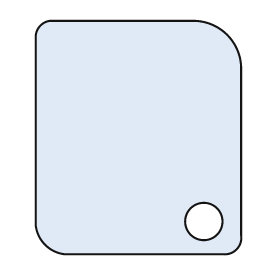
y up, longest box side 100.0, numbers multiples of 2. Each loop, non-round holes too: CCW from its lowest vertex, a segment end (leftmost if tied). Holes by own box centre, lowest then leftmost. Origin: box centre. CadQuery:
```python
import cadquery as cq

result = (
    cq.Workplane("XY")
    .moveTo(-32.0, -50.0)
    .lineTo(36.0, -50.0)
    .threePointArc((42.0, -48.0), (44.0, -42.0))
    .lineTo(44.0, 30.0)
    .threePointArc((38.0, 44.0), (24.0, 50.0))
    .lineTo(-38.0, 50.0)
    .threePointArc((-42.0, 48.0), (-44.0, 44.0))
    .lineTo(-44.0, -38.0)
    .threePointArc((-40.0, -46.0), (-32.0, -50.0))
    .close()
    .moveTo(28.0, -36.0)
    .circle(8.0)
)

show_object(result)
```